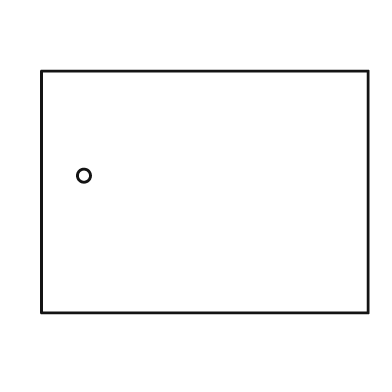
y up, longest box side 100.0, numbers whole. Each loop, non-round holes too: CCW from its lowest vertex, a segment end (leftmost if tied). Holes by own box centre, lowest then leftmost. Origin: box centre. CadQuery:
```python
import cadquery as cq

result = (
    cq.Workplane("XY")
    .moveTo(-50.0, -37.0)
    .lineTo(50.0, -37.0)
    .lineTo(50.0, 37.0)
    .lineTo(-50.0, 37.0)
    .close()
    .moveTo(-37.0, 5.0)
    .circle(2.0)
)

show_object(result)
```